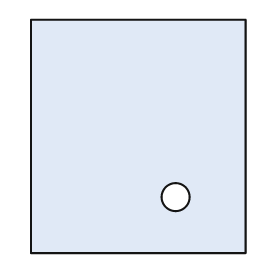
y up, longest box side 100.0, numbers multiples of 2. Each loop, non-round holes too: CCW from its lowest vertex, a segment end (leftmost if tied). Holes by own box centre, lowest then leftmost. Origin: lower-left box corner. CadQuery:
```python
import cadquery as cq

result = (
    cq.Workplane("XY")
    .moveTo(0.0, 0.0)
    .lineTo(92.0, 0.0)
    .lineTo(92.0, 100.0)
    .lineTo(0.0, 100.0)
    .close()
    .moveTo(62.0, 24.0)
    .circle(6.0)
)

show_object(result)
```